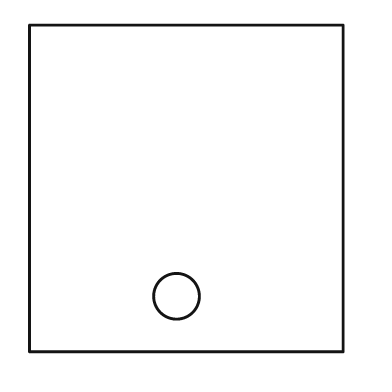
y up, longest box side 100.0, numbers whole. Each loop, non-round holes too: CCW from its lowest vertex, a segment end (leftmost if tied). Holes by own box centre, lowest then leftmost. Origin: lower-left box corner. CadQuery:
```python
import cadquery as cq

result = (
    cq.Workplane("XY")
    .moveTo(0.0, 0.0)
    .lineTo(96.0, 0.0)
    .lineTo(96.0, 100.0)
    .lineTo(0.0, 100.0)
    .close()
    .moveTo(45.0, 17.0)
    .circle(7.0)
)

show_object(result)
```